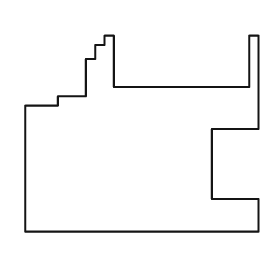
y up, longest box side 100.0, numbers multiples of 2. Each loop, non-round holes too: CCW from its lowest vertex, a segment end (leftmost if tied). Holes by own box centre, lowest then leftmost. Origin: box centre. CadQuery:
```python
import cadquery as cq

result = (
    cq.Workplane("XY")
    .moveTo(-50.0, -42.0)
    .lineTo(50.0, -42.0)
    .lineTo(50.0, -28.0)
    .lineTo(30.0, -28.0)
    .lineTo(30.0, 2.0)
    .lineTo(50.0, 2.0)
    .lineTo(50.0, 42.0)
    .lineTo(46.0, 42.0)
    .lineTo(46.0, 20.0)
    .lineTo(-12.0, 20.0)
    .lineTo(-12.0, 42.0)
    .lineTo(-16.0, 42.0)
    .lineTo(-16.0, 38.0)
    .lineTo(-20.0, 38.0)
    .lineTo(-20.0, 32.0)
    .lineTo(-24.0, 32.0)
    .lineTo(-24.0, 16.0)
    .lineTo(-36.0, 16.0)
    .lineTo(-36.0, 12.0)
    .lineTo(-50.0, 12.0)
    .close()
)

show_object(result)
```